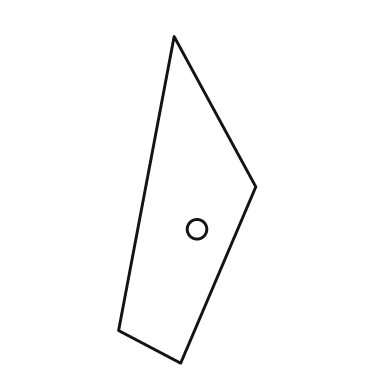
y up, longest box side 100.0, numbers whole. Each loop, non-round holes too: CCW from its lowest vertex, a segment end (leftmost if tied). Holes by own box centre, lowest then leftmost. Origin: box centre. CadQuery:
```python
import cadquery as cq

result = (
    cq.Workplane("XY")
    .moveTo(-2.0, -50.0)
    .lineTo(21.0, 4.0)
    .lineTo(-4.0, 50.0)
    .lineTo(-21.0, -40.0)
    .close()
    .moveTo(3.0, -9.0)
    .circle(3.0)
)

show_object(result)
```